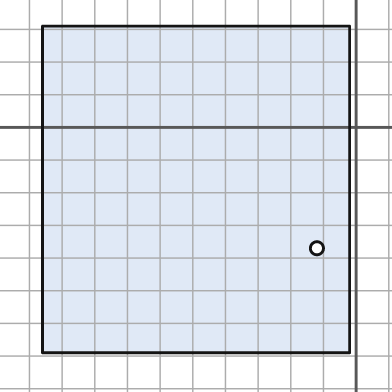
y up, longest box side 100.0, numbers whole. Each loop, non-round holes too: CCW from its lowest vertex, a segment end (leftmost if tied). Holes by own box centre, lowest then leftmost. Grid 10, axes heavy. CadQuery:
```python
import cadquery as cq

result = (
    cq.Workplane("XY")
    .moveTo(-96.0, -69.0)
    .lineTo(-2.0, -69.0)
    .lineTo(-2.0, 31.0)
    .lineTo(-96.0, 31.0)
    .close()
    .moveTo(-12.0, -37.0)
    .circle(2.0)
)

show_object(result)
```